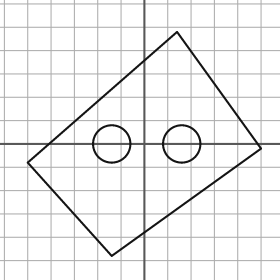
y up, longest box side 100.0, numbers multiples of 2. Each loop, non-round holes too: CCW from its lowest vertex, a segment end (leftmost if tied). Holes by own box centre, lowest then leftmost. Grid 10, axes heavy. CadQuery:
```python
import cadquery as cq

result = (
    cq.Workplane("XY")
    .moveTo(-14.0, -48.0)
    .lineTo(50.0, -2.0)
    .lineTo(14.0, 48.0)
    .lineTo(-50.0, -8.0)
    .close()
    .moveTo(-14.0, 0.0)
    .circle(8.0)
    .moveTo(16.0, 0.0)
    .circle(8.0)
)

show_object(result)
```